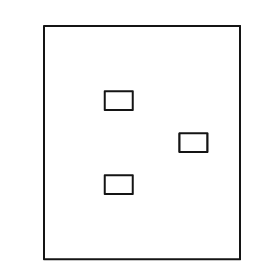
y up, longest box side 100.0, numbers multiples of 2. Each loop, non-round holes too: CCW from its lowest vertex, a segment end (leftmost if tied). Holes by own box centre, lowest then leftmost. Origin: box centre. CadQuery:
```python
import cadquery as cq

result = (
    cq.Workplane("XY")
    .moveTo(-42.0, -50.0)
    .lineTo(42.0, -50.0)
    .lineTo(42.0, 50.0)
    .lineTo(-42.0, 50.0)
    .close()
    .moveTo(-16.0, -22.0)
    .lineTo(-4.0, -22.0)
    .lineTo(-4.0, -14.0)
    .lineTo(-16.0, -14.0)
    .close()
    .moveTo(16.0, -4.0)
    .lineTo(28.0, -4.0)
    .lineTo(28.0, 4.0)
    .lineTo(16.0, 4.0)
    .close()
    .moveTo(-16.0, 14.0)
    .lineTo(-4.0, 14.0)
    .lineTo(-4.0, 22.0)
    .lineTo(-16.0, 22.0)
    .close()
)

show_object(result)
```